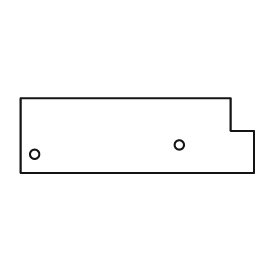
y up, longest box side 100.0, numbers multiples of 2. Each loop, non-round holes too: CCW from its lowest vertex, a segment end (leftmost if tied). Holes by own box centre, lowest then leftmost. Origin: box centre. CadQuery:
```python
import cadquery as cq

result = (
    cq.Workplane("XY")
    .moveTo(-50.0, -16.0)
    .lineTo(50.0, -16.0)
    .lineTo(50.0, 2.0)
    .lineTo(40.0, 2.0)
    .lineTo(40.0, 16.0)
    .lineTo(-50.0, 16.0)
    .close()
    .moveTo(-44.0, -8.0)
    .circle(2.0)
    .moveTo(18.0, -4.0)
    .circle(2.0)
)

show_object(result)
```